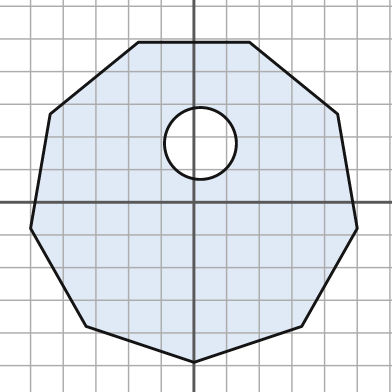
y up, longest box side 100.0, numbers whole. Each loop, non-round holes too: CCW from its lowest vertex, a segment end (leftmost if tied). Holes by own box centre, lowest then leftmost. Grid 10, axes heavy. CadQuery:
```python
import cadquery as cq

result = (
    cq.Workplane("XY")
    .moveTo(0.0, -49.0)
    .lineTo(33.0, -38.0)
    .lineTo(50.0, -8.0)
    .lineTo(44.0, 27.0)
    .lineTo(17.0, 49.0)
    .lineTo(-17.0, 49.0)
    .lineTo(-44.0, 27.0)
    .lineTo(-50.0, -8.0)
    .lineTo(-33.0, -38.0)
    .close()
    .moveTo(2.0, 18.0)
    .circle(11.0)
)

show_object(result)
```